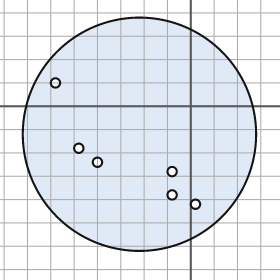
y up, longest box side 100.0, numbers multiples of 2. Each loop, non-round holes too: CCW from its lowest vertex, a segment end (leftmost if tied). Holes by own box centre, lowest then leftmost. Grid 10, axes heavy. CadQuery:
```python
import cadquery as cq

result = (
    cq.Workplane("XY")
    .moveTo(-22.0, -12.0)
    .circle(50.0)
    .moveTo(2.0, -42.0)
    .circle(2.0)
    .moveTo(-8.0, -38.0)
    .circle(2.0)
    .moveTo(-8.0, -28.0)
    .circle(2.0)
    .moveTo(-40.0, -24.0)
    .circle(2.0)
    .moveTo(-48.0, -18.0)
    .circle(2.0)
    .moveTo(-58.0, 10.0)
    .circle(2.0)
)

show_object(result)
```